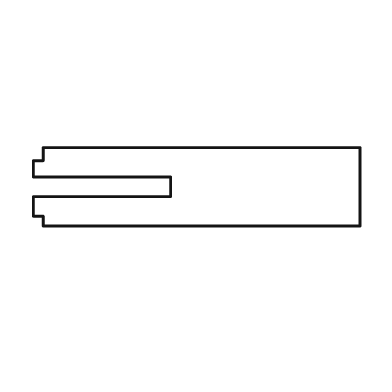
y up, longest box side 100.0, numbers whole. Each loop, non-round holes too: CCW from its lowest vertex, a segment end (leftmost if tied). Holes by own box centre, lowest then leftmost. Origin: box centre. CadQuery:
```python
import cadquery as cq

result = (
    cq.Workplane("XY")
    .moveTo(-47.0, -12.0)
    .lineTo(50.0, -12.0)
    .lineTo(50.0, 12.0)
    .lineTo(-47.0, 12.0)
    .lineTo(-47.0, 8.0)
    .lineTo(-50.0, 8.0)
    .lineTo(-50.0, 3.0)
    .lineTo(-8.0, 3.0)
    .lineTo(-8.0, -3.0)
    .lineTo(-50.0, -3.0)
    .lineTo(-50.0, -9.0)
    .lineTo(-47.0, -9.0)
    .close()
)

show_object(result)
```